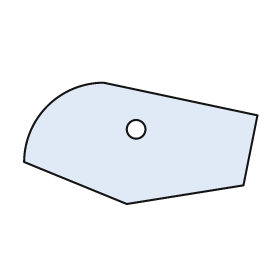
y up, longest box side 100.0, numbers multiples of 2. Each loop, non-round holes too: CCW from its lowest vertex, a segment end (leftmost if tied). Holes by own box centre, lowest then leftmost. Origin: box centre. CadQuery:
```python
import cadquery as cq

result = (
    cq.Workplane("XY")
    .moveTo(-6.0, -26.0)
    .lineTo(44.0, -18.0)
    .lineTo(50.0, 12.0)
    .lineTo(-16.0, 26.0)
    .threePointArc((-40.0, 16.0), (-50.0, -8.0))
    .close()
    .moveTo(-2.0, 6.0)
    .circle(4.0)
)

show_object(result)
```